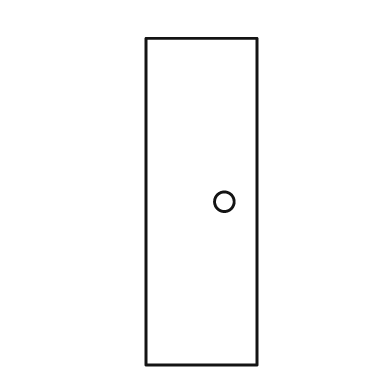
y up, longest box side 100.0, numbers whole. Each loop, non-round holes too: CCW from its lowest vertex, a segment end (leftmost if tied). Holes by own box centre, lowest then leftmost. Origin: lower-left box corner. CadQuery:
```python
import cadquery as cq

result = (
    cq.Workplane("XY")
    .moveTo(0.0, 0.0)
    .lineTo(34.0, 0.0)
    .lineTo(34.0, 100.0)
    .lineTo(0.0, 100.0)
    .close()
    .moveTo(24.0, 50.0)
    .circle(3.0)
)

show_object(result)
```